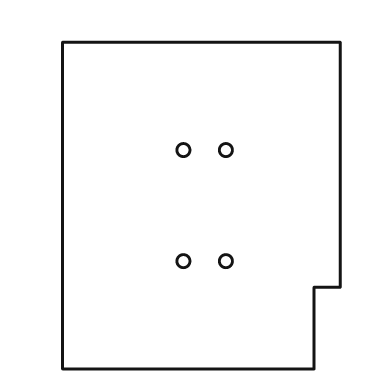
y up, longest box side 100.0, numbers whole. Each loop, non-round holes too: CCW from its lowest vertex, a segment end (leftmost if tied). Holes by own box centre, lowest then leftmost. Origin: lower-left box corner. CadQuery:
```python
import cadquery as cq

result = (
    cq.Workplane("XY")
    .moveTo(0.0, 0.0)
    .lineTo(77.0, 0.0)
    .lineTo(77.0, 25.0)
    .lineTo(85.0, 25.0)
    .lineTo(85.0, 100.0)
    .lineTo(0.0, 100.0)
    .close()
    .moveTo(37.0, 33.0)
    .circle(2.0)
    .moveTo(50.0, 33.0)
    .circle(2.0)
    .moveTo(37.0, 67.0)
    .circle(2.0)
    .moveTo(50.0, 67.0)
    .circle(2.0)
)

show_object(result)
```